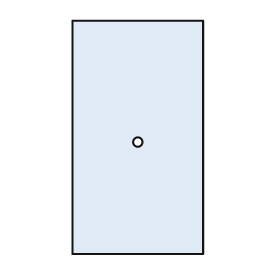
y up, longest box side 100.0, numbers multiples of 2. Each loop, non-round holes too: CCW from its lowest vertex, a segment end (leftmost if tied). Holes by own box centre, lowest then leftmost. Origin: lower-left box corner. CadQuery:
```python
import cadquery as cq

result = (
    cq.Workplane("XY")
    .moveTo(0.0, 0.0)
    .lineTo(56.0, 0.0)
    .lineTo(56.0, 100.0)
    .lineTo(0.0, 100.0)
    .close()
    .moveTo(28.0, 48.0)
    .circle(2.0)
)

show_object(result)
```